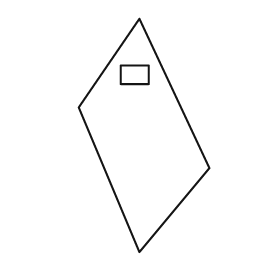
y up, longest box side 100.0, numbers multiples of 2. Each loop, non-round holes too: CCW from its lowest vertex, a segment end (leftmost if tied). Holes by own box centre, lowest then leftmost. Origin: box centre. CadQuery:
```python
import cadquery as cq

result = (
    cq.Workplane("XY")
    .moveTo(-2.0, -50.0)
    .lineTo(28.0, -14.0)
    .lineTo(-2.0, 50.0)
    .lineTo(-28.0, 12.0)
    .close()
    .moveTo(-10.0, 22.0)
    .lineTo(2.0, 22.0)
    .lineTo(2.0, 30.0)
    .lineTo(-10.0, 30.0)
    .close()
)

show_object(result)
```